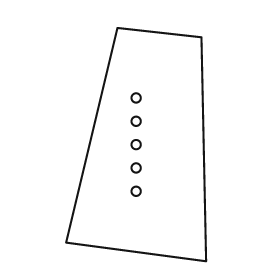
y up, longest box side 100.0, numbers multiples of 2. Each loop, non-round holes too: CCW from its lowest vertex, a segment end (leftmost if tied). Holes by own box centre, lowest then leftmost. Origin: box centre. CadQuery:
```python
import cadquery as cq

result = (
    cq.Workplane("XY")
    .moveTo(30.0, -50.0)
    .lineTo(28.0, 46.0)
    .lineTo(-8.0, 50.0)
    .lineTo(-30.0, -42.0)
    .close()
    .moveTo(0.0, -20.0)
    .circle(2.0)
    .moveTo(0.0, -10.0)
    .circle(2.0)
    .moveTo(0.0, 0.0)
    .circle(2.0)
    .moveTo(0.0, 10.0)
    .circle(2.0)
    .moveTo(0.0, 20.0)
    .circle(2.0)
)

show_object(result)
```